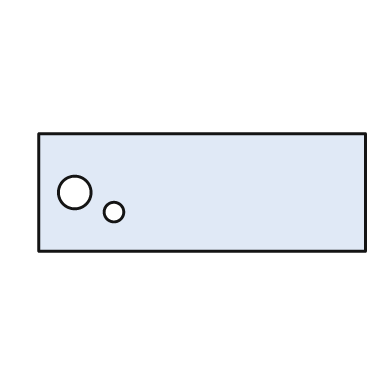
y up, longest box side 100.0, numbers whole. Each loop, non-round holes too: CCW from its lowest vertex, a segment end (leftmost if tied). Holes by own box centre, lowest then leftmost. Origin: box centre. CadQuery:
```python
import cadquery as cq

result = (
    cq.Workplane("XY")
    .moveTo(-50.0, -18.0)
    .lineTo(50.0, -18.0)
    .lineTo(50.0, 18.0)
    .lineTo(-50.0, 18.0)
    .close()
    .moveTo(-27.0, -6.0)
    .circle(3.0)
    .moveTo(-39.0, 0.0)
    .circle(5.0)
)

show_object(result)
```